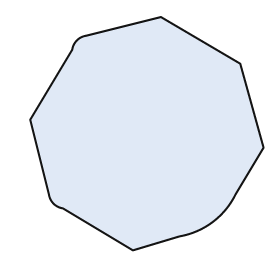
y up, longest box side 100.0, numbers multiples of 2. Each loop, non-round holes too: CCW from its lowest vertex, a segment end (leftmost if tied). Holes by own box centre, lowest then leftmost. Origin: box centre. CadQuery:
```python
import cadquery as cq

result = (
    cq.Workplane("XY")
    .moveTo(-6.0, -50.0)
    .lineTo(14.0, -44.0)
    .threePointArc((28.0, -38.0), (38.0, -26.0))
    .lineTo(50.0, -6.0)
    .lineTo(40.0, 30.0)
    .lineTo(6.0, 50.0)
    .lineTo(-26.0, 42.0)
    .threePointArc((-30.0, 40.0), (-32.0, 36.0))
    .lineTo(-50.0, 6.0)
    .lineTo(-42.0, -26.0)
    .threePointArc((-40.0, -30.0), (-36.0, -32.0))
    .close()
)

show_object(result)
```